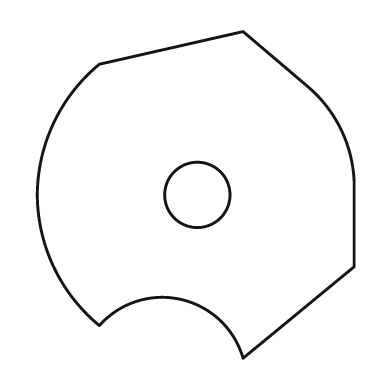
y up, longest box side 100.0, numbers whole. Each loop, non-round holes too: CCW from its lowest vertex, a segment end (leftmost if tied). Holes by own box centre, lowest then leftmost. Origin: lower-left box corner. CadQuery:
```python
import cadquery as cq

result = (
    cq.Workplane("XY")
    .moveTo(63.0, 0.0)
    .lineTo(97.0, 28.0)
    .lineTo(97.0, 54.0)
    .threePointArc((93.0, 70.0), (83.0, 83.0))
    .lineTo(63.0, 100.0)
    .lineTo(19.0, 90.0)
    .threePointArc((5.0, 72.0), (0.0, 50.0))
    .threePointArc((5.0, 28.0), (19.0, 10.0))
    .threePointArc((44.0, 18.0), (63.0, 0.0))
    .close()
    .moveTo(49.0, 50.0)
    .circle(10.0)
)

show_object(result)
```